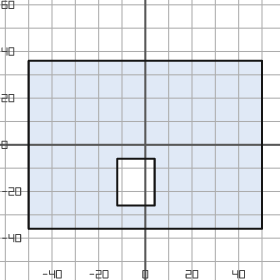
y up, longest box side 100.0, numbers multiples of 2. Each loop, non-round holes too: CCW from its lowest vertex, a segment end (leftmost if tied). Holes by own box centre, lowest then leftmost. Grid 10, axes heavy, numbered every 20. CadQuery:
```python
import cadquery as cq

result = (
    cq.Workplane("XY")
    .moveTo(-50.0, -36.0)
    .lineTo(50.0, -36.0)
    .lineTo(50.0, 36.0)
    .lineTo(-50.0, 36.0)
    .close()
    .moveTo(-12.0, -26.0)
    .lineTo(4.0, -26.0)
    .lineTo(4.0, -6.0)
    .lineTo(-12.0, -6.0)
    .close()
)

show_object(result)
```